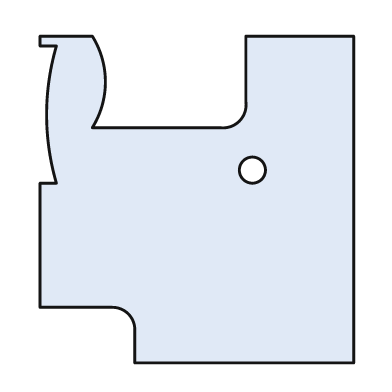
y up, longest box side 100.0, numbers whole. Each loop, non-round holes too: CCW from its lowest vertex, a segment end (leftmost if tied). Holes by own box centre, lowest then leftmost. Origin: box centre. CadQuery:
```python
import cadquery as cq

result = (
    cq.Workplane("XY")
    .moveTo(-19.0, -50.0)
    .lineTo(48.0, -50.0)
    .lineTo(48.0, 50.0)
    .lineTo(15.0, 50.0)
    .lineTo(15.0, 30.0)
    .threePointArc((13.0, 24.0), (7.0, 22.0))
    .lineTo(-32.0, 22.0)
    .threePointArc((-28.0, 36.0), (-32.0, 50.0))
    .lineTo(-48.0, 50.0)
    .lineTo(-48.0, 47.0)
    .lineTo(-43.0, 47.0)
    .threePointArc((-46.0, 26.0), (-43.0, 5.0))
    .lineTo(-48.0, 5.0)
    .lineTo(-48.0, -33.0)
    .lineTo(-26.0, -33.0)
    .threePointArc((-21.0, -35.0), (-19.0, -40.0))
    .close()
    .moveTo(17.0, 9.0)
    .circle(4.0)
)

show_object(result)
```